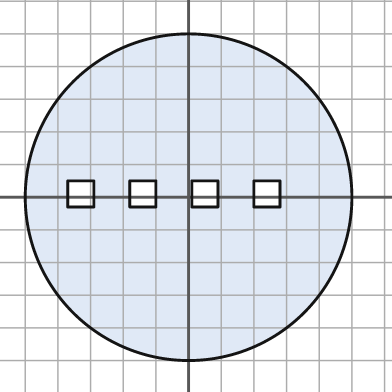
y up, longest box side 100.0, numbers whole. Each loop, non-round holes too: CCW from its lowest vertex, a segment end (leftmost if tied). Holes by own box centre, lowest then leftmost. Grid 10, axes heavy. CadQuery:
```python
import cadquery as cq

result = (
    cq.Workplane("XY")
    .moveTo(0.0, 0.0)
    .circle(50.0)
    .moveTo(-37.0, -3.0)
    .lineTo(-29.0, -3.0)
    .lineTo(-29.0, 5.0)
    .lineTo(-37.0, 5.0)
    .close()
    .moveTo(-18.0, -3.0)
    .lineTo(-10.0, -3.0)
    .lineTo(-10.0, 5.0)
    .lineTo(-18.0, 5.0)
    .close()
    .moveTo(1.0, -3.0)
    .lineTo(9.0, -3.0)
    .lineTo(9.0, 5.0)
    .lineTo(1.0, 5.0)
    .close()
    .moveTo(20.0, -3.0)
    .lineTo(28.0, -3.0)
    .lineTo(28.0, 5.0)
    .lineTo(20.0, 5.0)
    .close()
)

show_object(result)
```